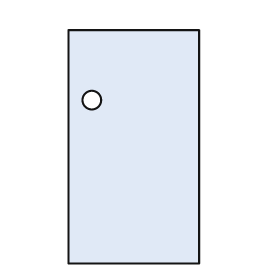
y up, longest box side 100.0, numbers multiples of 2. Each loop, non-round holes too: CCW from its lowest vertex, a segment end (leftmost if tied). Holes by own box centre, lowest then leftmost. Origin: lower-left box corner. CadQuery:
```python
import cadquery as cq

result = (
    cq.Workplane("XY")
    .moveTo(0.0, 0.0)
    .lineTo(56.0, 0.0)
    .lineTo(56.0, 100.0)
    .lineTo(0.0, 100.0)
    .close()
    .moveTo(10.0, 70.0)
    .circle(4.0)
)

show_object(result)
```